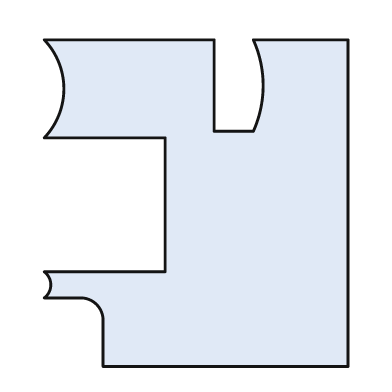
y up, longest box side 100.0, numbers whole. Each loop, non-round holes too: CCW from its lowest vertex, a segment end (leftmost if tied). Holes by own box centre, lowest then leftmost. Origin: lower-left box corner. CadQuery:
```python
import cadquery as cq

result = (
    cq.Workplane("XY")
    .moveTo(18.0, 0.0)
    .lineTo(93.0, 0.0)
    .lineTo(93.0, 100.0)
    .lineTo(64.0, 100.0)
    .threePointArc((67.0, 86.0), (64.0, 72.0))
    .lineTo(52.0, 72.0)
    .lineTo(52.0, 100.0)
    .lineTo(0.0, 100.0)
    .threePointArc((6.0, 85.0), (0.0, 70.0))
    .lineTo(37.0, 70.0)
    .lineTo(37.0, 29.0)
    .lineTo(0.0, 29.0)
    .threePointArc((2.0, 25.0), (0.0, 21.0))
    .lineTo(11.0, 21.0)
    .threePointArc((16.0, 19.0), (18.0, 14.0))
    .close()
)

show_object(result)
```